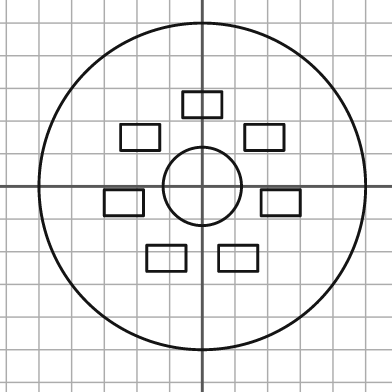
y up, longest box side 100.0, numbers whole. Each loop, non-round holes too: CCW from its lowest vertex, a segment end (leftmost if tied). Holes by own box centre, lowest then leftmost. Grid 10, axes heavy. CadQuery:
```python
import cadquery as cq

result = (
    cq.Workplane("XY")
    .moveTo(0.0, 0.0)
    .circle(50.0)
    .moveTo(-17.0, -26.0)
    .lineTo(-5.0, -26.0)
    .lineTo(-5.0, -18.0)
    .lineTo(-17.0, -18.0)
    .close()
    .moveTo(5.0, -26.0)
    .lineTo(17.0, -26.0)
    .lineTo(17.0, -18.0)
    .lineTo(5.0, -18.0)
    .close()
    .moveTo(-30.0, -9.0)
    .lineTo(-18.0, -9.0)
    .lineTo(-18.0, -1.0)
    .lineTo(-30.0, -1.0)
    .close()
    .moveTo(18.0, -9.0)
    .lineTo(30.0, -9.0)
    .lineTo(30.0, -1.0)
    .lineTo(18.0, -1.0)
    .close()
    .moveTo(0.0, 0.0)
    .circle(12.0)
    .moveTo(-25.0, 11.0)
    .lineTo(-13.0, 11.0)
    .lineTo(-13.0, 19.0)
    .lineTo(-25.0, 19.0)
    .close()
    .moveTo(13.0, 11.0)
    .lineTo(25.0, 11.0)
    .lineTo(25.0, 19.0)
    .lineTo(13.0, 19.0)
    .close()
    .moveTo(-6.0, 21.0)
    .lineTo(6.0, 21.0)
    .lineTo(6.0, 29.0)
    .lineTo(-6.0, 29.0)
    .close()
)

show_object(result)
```